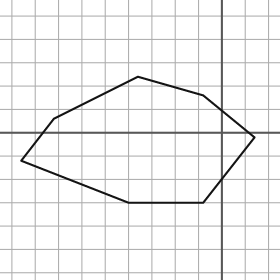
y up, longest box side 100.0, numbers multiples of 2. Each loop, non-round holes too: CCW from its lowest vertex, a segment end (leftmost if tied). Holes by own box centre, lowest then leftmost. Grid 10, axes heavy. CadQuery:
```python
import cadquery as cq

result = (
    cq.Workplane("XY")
    .moveTo(-40.0, -30.0)
    .lineTo(-8.0, -30.0)
    .lineTo(14.0, -2.0)
    .lineTo(-8.0, 16.0)
    .lineTo(-36.0, 24.0)
    .lineTo(-72.0, 6.0)
    .lineTo(-86.0, -12.0)
    .close()
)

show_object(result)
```